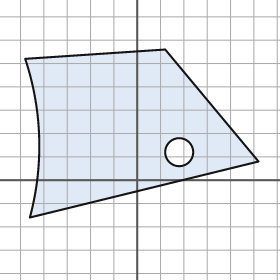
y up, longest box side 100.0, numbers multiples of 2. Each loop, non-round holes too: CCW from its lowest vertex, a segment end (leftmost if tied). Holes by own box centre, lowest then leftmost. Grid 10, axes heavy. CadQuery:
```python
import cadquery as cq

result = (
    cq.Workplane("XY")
    .moveTo(-46.0, -16.0)
    .lineTo(52.0, 8.0)
    .lineTo(12.0, 56.0)
    .lineTo(-48.0, 52.0)
    .threePointArc((-42.0, 18.0), (-46.0, -16.0))
    .close()
    .moveTo(18.0, 12.0)
    .circle(6.0)
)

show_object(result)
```